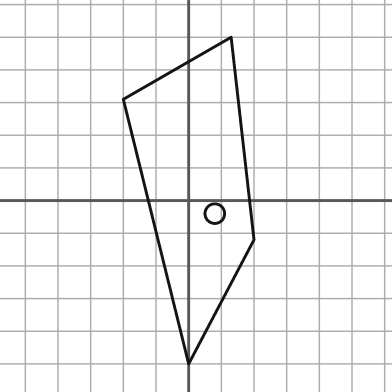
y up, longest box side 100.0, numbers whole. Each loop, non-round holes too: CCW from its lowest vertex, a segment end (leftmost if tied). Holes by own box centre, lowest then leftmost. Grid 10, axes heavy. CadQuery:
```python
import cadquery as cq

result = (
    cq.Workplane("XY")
    .moveTo(0.0, -50.0)
    .lineTo(20.0, -12.0)
    .lineTo(13.0, 50.0)
    .lineTo(-20.0, 31.0)
    .close()
    .moveTo(8.0, -4.0)
    .circle(3.0)
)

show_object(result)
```